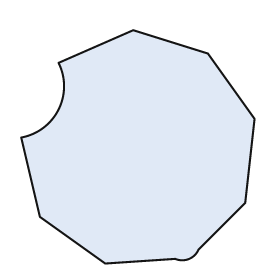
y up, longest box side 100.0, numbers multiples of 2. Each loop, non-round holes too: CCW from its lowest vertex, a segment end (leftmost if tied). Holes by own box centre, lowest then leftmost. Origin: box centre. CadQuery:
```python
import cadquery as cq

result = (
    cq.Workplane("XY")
    .moveTo(-14.0, -50.0)
    .lineTo(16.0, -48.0)
    .threePointArc((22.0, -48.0), (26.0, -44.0))
    .lineTo(46.0, -24.0)
    .lineTo(50.0, 12.0)
    .lineTo(30.0, 40.0)
    .lineTo(-2.0, 50.0)
    .lineTo(-34.0, 36.0)
    .threePointArc((-34.0, 16.0), (-50.0, 4.0))
    .lineTo(-42.0, -30.0)
    .close()
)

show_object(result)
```